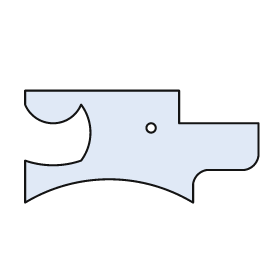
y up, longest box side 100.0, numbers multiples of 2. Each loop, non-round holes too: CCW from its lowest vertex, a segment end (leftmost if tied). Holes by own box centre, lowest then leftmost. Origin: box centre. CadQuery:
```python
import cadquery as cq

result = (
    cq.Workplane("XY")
    .moveTo(-50.0, -24.0)
    .threePointArc((-14.0, -14.0), (22.0, -24.0))
    .lineTo(22.0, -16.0)
    .threePointArc((24.0, -12.0), (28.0, -10.0))
    .lineTo(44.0, -10.0)
    .threePointArc((48.0, -8.0), (50.0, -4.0))
    .lineTo(50.0, 10.0)
    .lineTo(16.0, 10.0)
    .lineTo(16.0, 24.0)
    .lineTo(-50.0, 24.0)
    .lineTo(-50.0, 18.0)
    .threePointArc((-38.0, 10.0), (-26.0, 18.0))
    .threePointArc((-22.0, 6.0), (-26.0, -6.0))
    .threePointArc((-38.0, -8.0), (-50.0, -6.0))
    .close()
    .moveTo(4.0, 8.0)
    .circle(2.0)
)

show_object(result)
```